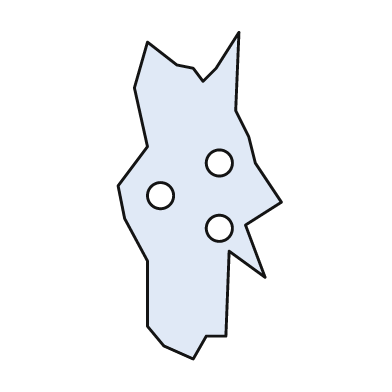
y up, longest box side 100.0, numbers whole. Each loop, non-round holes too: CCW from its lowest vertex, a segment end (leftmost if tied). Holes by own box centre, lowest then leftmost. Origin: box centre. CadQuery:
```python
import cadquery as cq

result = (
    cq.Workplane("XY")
    .moveTo(-2.0, -50.0)
    .lineTo(2.0, -43.0)
    .lineTo(8.0, -43.0)
    .lineTo(9.0, -17.0)
    .lineTo(20.0, -25.0)
    .lineTo(14.0, -9.0)
    .lineTo(25.0, -2.0)
    .lineTo(17.0, 10.0)
    .lineTo(15.0, 18.0)
    .lineTo(11.0, 26.0)
    .lineTo(12.0, 50.0)
    .lineTo(5.0, 39.0)
    .lineTo(1.0, 35.0)
    .lineTo(-2.0, 39.0)
    .lineTo(-7.0, 40.0)
    .lineTo(-16.0, 47.0)
    .lineTo(-20.0, 33.0)
    .lineTo(-16.0, 15.0)
    .lineTo(-25.0, 3.0)
    .lineTo(-23.0, -7.0)
    .lineTo(-16.0, -20.0)
    .lineTo(-16.0, -40.0)
    .lineTo(-11.0, -46.0)
    .close()
    .moveTo(6.0, -10.0)
    .circle(4.0)
    .moveTo(-12.0, 0.0)
    .circle(4.0)
    .moveTo(6.0, 10.0)
    .circle(4.0)
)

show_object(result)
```